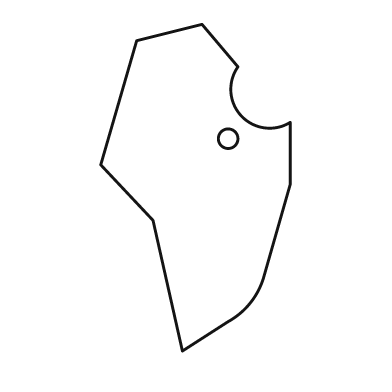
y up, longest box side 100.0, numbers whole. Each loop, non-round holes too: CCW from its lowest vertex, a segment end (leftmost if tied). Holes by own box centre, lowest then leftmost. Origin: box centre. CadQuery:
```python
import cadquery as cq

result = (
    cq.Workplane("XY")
    .moveTo(-4.0, -50.0)
    .lineTo(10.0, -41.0)
    .threePointArc((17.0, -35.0), (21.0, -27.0))
    .lineTo(29.0, 1.0)
    .lineTo(29.0, 20.0)
    .threePointArc((14.0, 22.0), (13.0, 37.0))
    .lineTo(2.0, 50.0)
    .lineTo(-18.0, 45.0)
    .lineTo(-29.0, 7.0)
    .lineTo(-13.0, -10.0)
    .close()
    .moveTo(10.0, 15.0)
    .circle(3.0)
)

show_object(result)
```